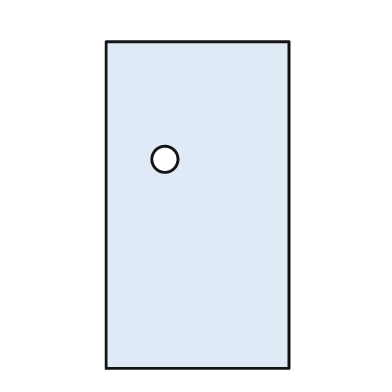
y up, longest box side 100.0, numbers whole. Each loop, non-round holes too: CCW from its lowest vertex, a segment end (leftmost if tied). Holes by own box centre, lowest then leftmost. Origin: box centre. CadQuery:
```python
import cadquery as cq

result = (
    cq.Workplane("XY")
    .moveTo(-28.0, -50.0)
    .lineTo(28.0, -50.0)
    .lineTo(28.0, 50.0)
    .lineTo(-28.0, 50.0)
    .close()
    .moveTo(-10.0, 14.0)
    .circle(4.0)
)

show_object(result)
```